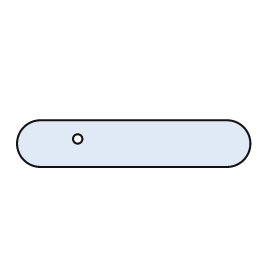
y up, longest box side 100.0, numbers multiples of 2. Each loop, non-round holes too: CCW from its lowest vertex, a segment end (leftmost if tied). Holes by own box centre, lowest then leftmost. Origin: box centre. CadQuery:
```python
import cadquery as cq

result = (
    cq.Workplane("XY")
    .moveTo(-40.0, -10.0)
    .lineTo(40.0, -10.0)
    .threePointArc((50.0, 0.0), (40.0, 10.0))
    .lineTo(-40.0, 10.0)
    .threePointArc((-50.0, 0.0), (-40.0, -10.0))
    .close()
    .moveTo(-24.0, 2.0)
    .circle(2.0)
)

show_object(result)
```